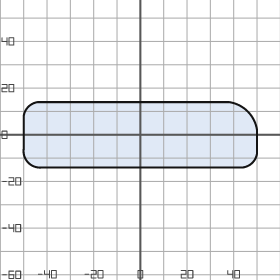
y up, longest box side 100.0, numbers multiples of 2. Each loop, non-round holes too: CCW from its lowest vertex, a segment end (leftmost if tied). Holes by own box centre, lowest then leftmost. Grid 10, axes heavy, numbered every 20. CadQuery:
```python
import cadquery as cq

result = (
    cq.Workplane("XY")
    .moveTo(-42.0, -14.0)
    .lineTo(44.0, -14.0)
    .threePointArc((48.0, -12.0), (50.0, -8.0))
    .lineTo(50.0, 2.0)
    .threePointArc((46.0, 10.0), (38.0, 14.0))
    .lineTo(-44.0, 14.0)
    .threePointArc((-48.0, 12.0), (-50.0, 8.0))
    .lineTo(-50.0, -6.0)
    .threePointArc((-48.0, -12.0), (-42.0, -14.0))
    .close()
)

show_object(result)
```